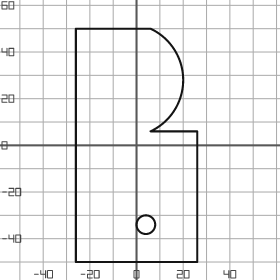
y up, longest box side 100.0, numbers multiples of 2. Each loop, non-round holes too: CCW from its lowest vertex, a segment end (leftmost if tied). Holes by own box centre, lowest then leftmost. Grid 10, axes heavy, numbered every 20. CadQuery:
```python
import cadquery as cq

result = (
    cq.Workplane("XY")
    .moveTo(-26.0, -50.0)
    .lineTo(26.0, -50.0)
    .lineTo(26.0, 6.0)
    .lineTo(6.0, 6.0)
    .threePointArc((20.0, 28.0), (6.0, 50.0))
    .lineTo(-26.0, 50.0)
    .close()
    .moveTo(4.0, -34.0)
    .circle(4.0)
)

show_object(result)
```